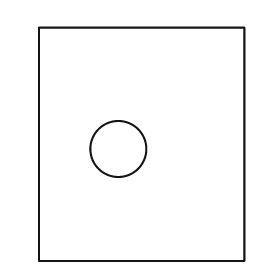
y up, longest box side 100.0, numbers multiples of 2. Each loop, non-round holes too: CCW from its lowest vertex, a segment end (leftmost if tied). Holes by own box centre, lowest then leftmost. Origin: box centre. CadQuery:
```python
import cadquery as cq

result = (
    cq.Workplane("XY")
    .moveTo(-44.0, -50.0)
    .lineTo(44.0, -50.0)
    .lineTo(44.0, 50.0)
    .lineTo(-44.0, 50.0)
    .close()
    .moveTo(-10.0, -2.0)
    .circle(12.0)
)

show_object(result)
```